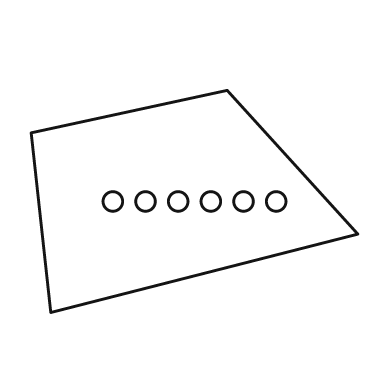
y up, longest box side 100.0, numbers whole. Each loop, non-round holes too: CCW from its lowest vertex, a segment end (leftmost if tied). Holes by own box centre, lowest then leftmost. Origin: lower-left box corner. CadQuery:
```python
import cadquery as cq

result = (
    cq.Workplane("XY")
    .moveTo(6.0, 0.0)
    .lineTo(100.0, 24.0)
    .lineTo(60.0, 68.0)
    .lineTo(0.0, 55.0)
    .close()
    .moveTo(25.0, 34.0)
    .circle(3.0)
    .moveTo(35.0, 34.0)
    .circle(3.0)
    .moveTo(45.0, 34.0)
    .circle(3.0)
    .moveTo(55.0, 34.0)
    .circle(3.0)
    .moveTo(65.0, 34.0)
    .circle(3.0)
    .moveTo(75.0, 34.0)
    .circle(3.0)
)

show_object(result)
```